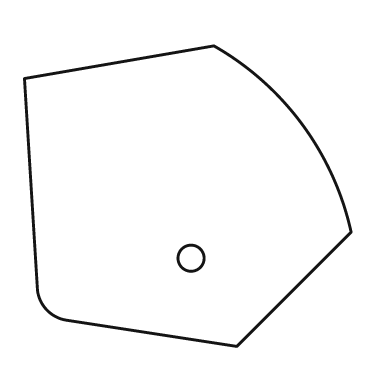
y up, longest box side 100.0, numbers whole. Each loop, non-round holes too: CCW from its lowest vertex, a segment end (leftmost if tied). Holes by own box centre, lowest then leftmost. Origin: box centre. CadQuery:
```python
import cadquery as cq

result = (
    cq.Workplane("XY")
    .moveTo(15.0, -46.0)
    .lineTo(50.0, -11.0)
    .threePointArc((35.0, 22.0), (8.0, 46.0))
    .lineTo(-50.0, 36.0)
    .lineTo(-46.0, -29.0)
    .threePointArc((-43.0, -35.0), (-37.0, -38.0))
    .close()
    .moveTo(1.0, -19.0)
    .circle(4.0)
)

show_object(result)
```